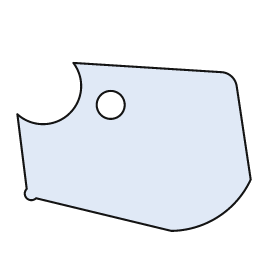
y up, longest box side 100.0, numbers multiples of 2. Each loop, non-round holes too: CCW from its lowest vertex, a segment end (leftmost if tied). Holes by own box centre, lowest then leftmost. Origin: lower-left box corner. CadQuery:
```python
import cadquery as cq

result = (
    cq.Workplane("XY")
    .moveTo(66.0, 0.0)
    .threePointArc((86.0, 6.0), (100.0, 22.0))
    .lineTo(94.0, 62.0)
    .threePointArc((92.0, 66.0), (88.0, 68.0))
    .lineTo(24.0, 72.0)
    .threePointArc((22.0, 50.0), (0.0, 50.0))
    .lineTo(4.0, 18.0)
    .threePointArc((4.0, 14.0), (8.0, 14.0))
    .close()
    .moveTo(40.0, 54.0)
    .circle(6.0)
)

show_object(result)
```